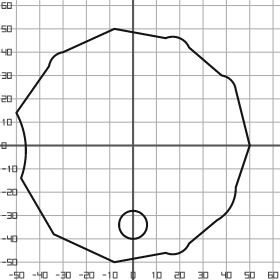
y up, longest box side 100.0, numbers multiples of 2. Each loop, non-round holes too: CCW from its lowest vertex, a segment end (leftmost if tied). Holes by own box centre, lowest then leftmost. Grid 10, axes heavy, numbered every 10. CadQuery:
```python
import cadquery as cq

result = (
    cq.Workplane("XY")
    .moveTo(-8.0, -50.0)
    .lineTo(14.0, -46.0)
    .threePointArc((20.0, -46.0), (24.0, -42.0))
    .lineTo(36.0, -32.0)
    .threePointArc((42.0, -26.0), (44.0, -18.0))
    .lineTo(50.0, 0.0)
    .lineTo(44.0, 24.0)
    .threePointArc((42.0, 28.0), (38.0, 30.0))
    .lineTo(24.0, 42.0)
    .threePointArc((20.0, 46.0), (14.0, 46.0))
    .lineTo(-8.0, 50.0)
    .lineTo(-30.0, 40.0)
    .threePointArc((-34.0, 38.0), (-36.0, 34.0))
    .lineTo(-50.0, 14.0)
    .threePointArc((-46.0, 0.0), (-48.0, -14.0))
    .lineTo(-34.0, -38.0)
    .close()
    .moveTo(0.0, -34.0)
    .circle(6.0)
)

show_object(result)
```